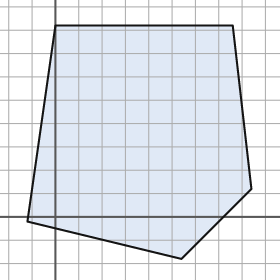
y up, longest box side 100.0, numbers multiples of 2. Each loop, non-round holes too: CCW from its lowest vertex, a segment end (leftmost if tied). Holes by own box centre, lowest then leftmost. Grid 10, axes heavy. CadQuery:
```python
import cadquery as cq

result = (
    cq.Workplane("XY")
    .moveTo(54.0, -18.0)
    .lineTo(84.0, 12.0)
    .lineTo(76.0, 82.0)
    .lineTo(0.0, 82.0)
    .lineTo(-12.0, -2.0)
    .close()
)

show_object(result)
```